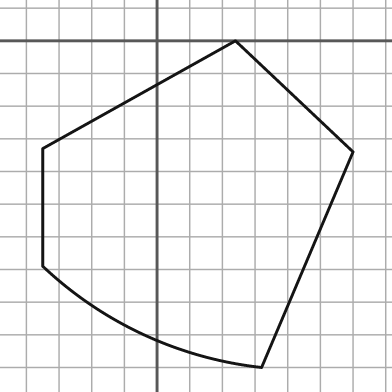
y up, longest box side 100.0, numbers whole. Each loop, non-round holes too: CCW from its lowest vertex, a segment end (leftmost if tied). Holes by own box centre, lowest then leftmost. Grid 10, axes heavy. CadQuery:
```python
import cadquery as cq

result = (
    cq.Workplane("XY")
    .moveTo(32.0, -100.0)
    .lineTo(60.0, -34.0)
    .lineTo(24.0, 0.0)
    .lineTo(-35.0, -33.0)
    .lineTo(-35.0, -69.0)
    .threePointArc((-4.0, -90.0), (32.0, -100.0))
    .close()
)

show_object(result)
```